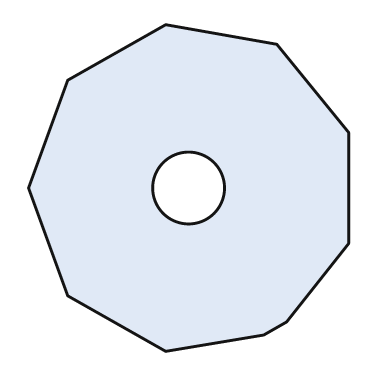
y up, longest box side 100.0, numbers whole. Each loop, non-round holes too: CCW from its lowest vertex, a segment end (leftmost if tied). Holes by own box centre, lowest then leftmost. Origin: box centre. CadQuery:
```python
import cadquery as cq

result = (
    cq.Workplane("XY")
    .moveTo(-7.0, -50.0)
    .lineTo(23.0, -45.0)
    .lineTo(30.0, -41.0)
    .lineTo(49.0, -17.0)
    .lineTo(49.0, 17.0)
    .lineTo(27.0, 44.0)
    .lineTo(-7.0, 50.0)
    .lineTo(-37.0, 33.0)
    .lineTo(-49.0, 0.0)
    .lineTo(-37.0, -33.0)
    .close()
    .moveTo(0.0, 0.0)
    .circle(11.0)
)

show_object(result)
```